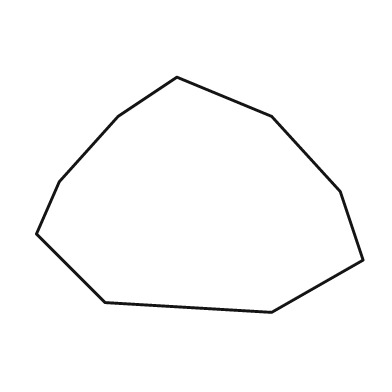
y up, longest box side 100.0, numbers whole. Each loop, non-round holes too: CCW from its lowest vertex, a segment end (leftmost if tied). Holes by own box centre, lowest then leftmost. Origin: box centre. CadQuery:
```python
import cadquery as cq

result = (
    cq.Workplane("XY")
    .moveTo(22.0, -36.0)
    .lineTo(50.0, -20.0)
    .lineTo(43.0, 1.0)
    .lineTo(22.0, 24.0)
    .lineTo(-7.0, 36.0)
    .lineTo(-25.0, 24.0)
    .lineTo(-43.0, 4.0)
    .lineTo(-50.0, -12.0)
    .lineTo(-29.0, -33.0)
    .close()
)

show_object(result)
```